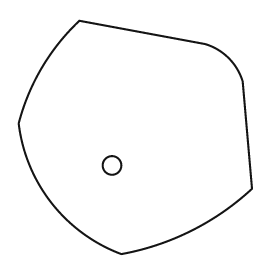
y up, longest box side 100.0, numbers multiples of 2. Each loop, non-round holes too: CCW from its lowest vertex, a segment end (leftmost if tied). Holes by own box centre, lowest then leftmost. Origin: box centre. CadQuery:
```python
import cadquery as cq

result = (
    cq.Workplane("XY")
    .moveTo(-6.0, -50.0)
    .threePointArc((24.0, -40.0), (50.0, -22.0))
    .lineTo(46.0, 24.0)
    .threePointArc((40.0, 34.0), (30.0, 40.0))
    .lineTo(-24.0, 50.0)
    .threePointArc((-40.0, 30.0), (-50.0, 6.0))
    .threePointArc((-36.0, -28.0), (-6.0, -50.0))
    .close()
    .moveTo(-10.0, -12.0)
    .circle(4.0)
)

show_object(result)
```